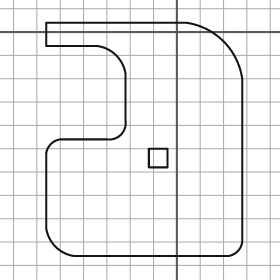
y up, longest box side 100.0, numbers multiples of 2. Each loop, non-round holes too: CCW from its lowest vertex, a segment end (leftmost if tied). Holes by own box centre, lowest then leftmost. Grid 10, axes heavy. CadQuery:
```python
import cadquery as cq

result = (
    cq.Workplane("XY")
    .moveTo(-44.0, -96.0)
    .lineTo(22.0, -96.0)
    .threePointArc((26.0, -94.0), (28.0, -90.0))
    .lineTo(28.0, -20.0)
    .threePointArc((20.0, -4.0), (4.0, 4.0))
    .lineTo(-56.0, 4.0)
    .lineTo(-56.0, -6.0)
    .lineTo(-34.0, -6.0)
    .threePointArc((-26.0, -10.0), (-22.0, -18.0))
    .lineTo(-22.0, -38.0)
    .threePointArc((-24.0, -44.0), (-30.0, -46.0))
    .lineTo(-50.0, -46.0)
    .threePointArc((-54.0, -48.0), (-56.0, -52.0))
    .lineTo(-56.0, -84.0)
    .threePointArc((-52.0, -92.0), (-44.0, -96.0))
    .close()
    .moveTo(-12.0, -58.0)
    .lineTo(-4.0, -58.0)
    .lineTo(-4.0, -50.0)
    .lineTo(-12.0, -50.0)
    .close()
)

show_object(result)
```